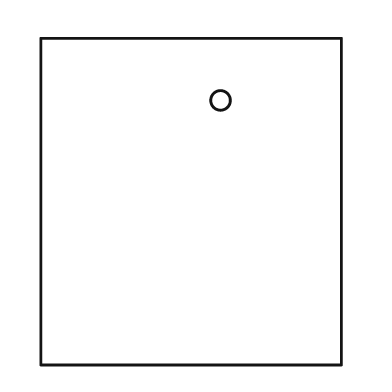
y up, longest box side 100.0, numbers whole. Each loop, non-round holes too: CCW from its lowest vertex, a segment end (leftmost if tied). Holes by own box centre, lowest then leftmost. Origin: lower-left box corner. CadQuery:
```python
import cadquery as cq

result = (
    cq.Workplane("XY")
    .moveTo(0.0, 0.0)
    .lineTo(92.0, 0.0)
    .lineTo(92.0, 100.0)
    .lineTo(0.0, 100.0)
    .close()
    .moveTo(55.0, 81.0)
    .circle(3.0)
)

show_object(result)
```